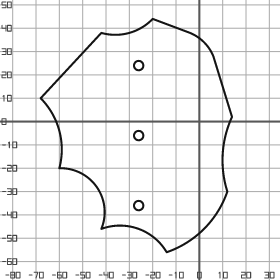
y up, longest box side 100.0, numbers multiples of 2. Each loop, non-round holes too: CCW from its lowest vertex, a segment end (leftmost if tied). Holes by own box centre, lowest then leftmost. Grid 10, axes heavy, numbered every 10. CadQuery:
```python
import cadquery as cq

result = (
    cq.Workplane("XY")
    .moveTo(-14.0, -56.0)
    .threePointArc((2.0, -46.0), (12.0, -30.0))
    .threePointArc((10.0, -14.0), (14.0, 2.0))
    .lineTo(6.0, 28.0)
    .threePointArc((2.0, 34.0), (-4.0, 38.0))
    .lineTo(-20.0, 44.0)
    .threePointArc((-30.0, 38.0), (-42.0, 38.0))
    .lineTo(-68.0, 10.0)
    .threePointArc((-60.0, -4.0), (-60.0, -20.0))
    .threePointArc((-44.0, -28.0), (-42.0, -46.0))
    .threePointArc((-26.0, -46.0), (-14.0, -56.0))
    .close()
    .moveTo(-26.0, -36.0)
    .circle(2.0)
    .moveTo(-26.0, -6.0)
    .circle(2.0)
    .moveTo(-26.0, 24.0)
    .circle(2.0)
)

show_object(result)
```